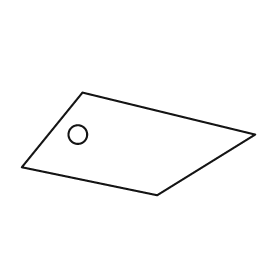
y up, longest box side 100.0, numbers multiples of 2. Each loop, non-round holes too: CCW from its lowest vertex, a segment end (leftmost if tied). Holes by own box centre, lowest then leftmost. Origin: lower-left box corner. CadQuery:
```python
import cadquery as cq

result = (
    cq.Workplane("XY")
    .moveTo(58.0, 0.0)
    .lineTo(100.0, 26.0)
    .lineTo(26.0, 44.0)
    .lineTo(0.0, 12.0)
    .close()
    .moveTo(24.0, 26.0)
    .circle(4.0)
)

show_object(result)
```